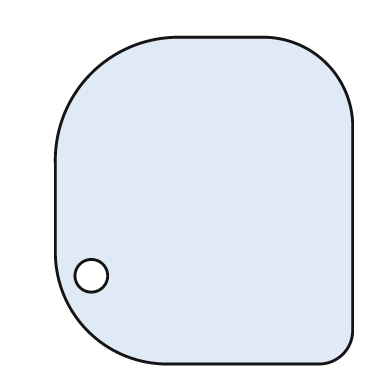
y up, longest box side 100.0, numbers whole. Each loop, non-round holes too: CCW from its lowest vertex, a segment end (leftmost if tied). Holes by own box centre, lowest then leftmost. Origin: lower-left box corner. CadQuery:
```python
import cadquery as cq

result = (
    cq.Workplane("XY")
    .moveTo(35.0, 0.0)
    .lineTo(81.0, 0.0)
    .threePointArc((88.0, 3.0), (91.0, 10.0))
    .lineTo(91.0, 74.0)
    .threePointArc((83.0, 92.0), (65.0, 100.0))
    .lineTo(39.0, 100.0)
    .threePointArc((11.0, 89.0), (0.0, 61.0))
    .lineTo(0.0, 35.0)
    .threePointArc((10.0, 10.0), (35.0, 0.0))
    .close()
    .moveTo(11.0, 27.0)
    .circle(5.0)
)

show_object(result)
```